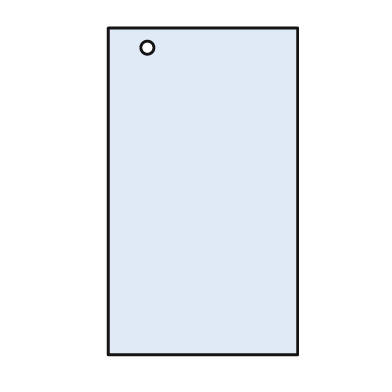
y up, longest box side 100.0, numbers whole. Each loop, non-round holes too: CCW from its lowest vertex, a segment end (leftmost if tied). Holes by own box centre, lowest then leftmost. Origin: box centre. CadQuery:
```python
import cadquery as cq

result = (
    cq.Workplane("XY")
    .moveTo(-29.0, -50.0)
    .lineTo(29.0, -50.0)
    .lineTo(29.0, 50.0)
    .lineTo(-29.0, 50.0)
    .close()
    .moveTo(-17.0, 44.0)
    .circle(2.0)
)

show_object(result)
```